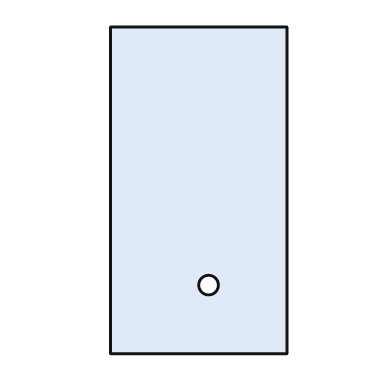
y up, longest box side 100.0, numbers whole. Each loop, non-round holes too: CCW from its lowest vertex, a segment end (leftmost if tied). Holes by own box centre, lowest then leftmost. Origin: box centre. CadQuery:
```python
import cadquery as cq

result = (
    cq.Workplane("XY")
    .moveTo(-27.0, -50.0)
    .lineTo(27.0, -50.0)
    .lineTo(27.0, 50.0)
    .lineTo(-27.0, 50.0)
    .close()
    .moveTo(3.0, -29.0)
    .circle(3.0)
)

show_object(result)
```